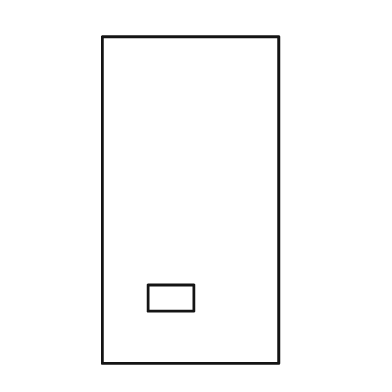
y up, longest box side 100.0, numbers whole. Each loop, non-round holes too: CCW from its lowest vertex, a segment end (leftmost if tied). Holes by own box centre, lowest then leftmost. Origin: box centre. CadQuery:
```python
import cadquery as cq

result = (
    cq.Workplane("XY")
    .moveTo(-27.0, -50.0)
    .lineTo(27.0, -50.0)
    .lineTo(27.0, 50.0)
    .lineTo(-27.0, 50.0)
    .close()
    .moveTo(-13.0, -34.0)
    .lineTo(1.0, -34.0)
    .lineTo(1.0, -26.0)
    .lineTo(-13.0, -26.0)
    .close()
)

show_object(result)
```